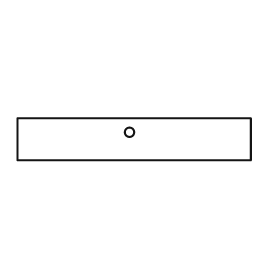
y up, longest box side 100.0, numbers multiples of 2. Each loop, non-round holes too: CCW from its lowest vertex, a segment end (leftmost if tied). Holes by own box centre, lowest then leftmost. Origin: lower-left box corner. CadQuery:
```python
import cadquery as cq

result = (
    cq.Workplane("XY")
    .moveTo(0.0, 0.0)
    .lineTo(100.0, 0.0)
    .lineTo(100.0, 18.0)
    .lineTo(0.0, 18.0)
    .close()
    .moveTo(48.0, 12.0)
    .circle(2.0)
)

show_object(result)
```